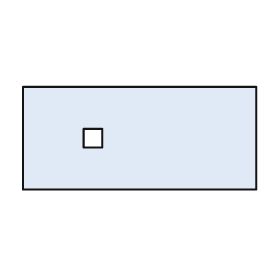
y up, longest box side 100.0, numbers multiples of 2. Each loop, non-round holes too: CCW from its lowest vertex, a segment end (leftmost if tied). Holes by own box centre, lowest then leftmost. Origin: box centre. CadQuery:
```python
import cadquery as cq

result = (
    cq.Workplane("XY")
    .moveTo(-50.0, -22.0)
    .lineTo(50.0, -22.0)
    .lineTo(50.0, 22.0)
    .lineTo(-50.0, 22.0)
    .close()
    .moveTo(-24.0, -4.0)
    .lineTo(-16.0, -4.0)
    .lineTo(-16.0, 4.0)
    .lineTo(-24.0, 4.0)
    .close()
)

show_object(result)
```